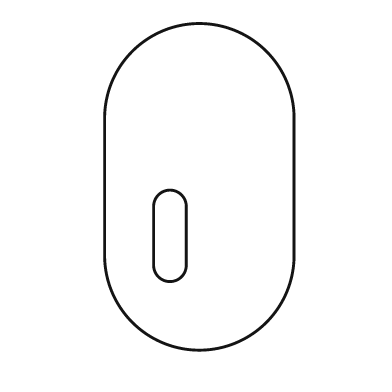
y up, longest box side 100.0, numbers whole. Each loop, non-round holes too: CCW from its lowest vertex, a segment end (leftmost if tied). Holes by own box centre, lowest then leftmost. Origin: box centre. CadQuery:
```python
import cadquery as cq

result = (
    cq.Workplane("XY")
    .moveTo(-29.0, -21.0)
    .threePointArc((0.0, -50.0), (29.0, -21.0))
    .lineTo(29.0, 21.0)
    .threePointArc((0.0, 50.0), (-29.0, 21.0))
    .close()
    .moveTo(-14.0, -24.0)
    .threePointArc((-9.0, -29.0), (-4.0, -24.0))
    .lineTo(-4.0, -6.0)
    .threePointArc((-9.0, -1.0), (-14.0, -6.0))
    .close()
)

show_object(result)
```